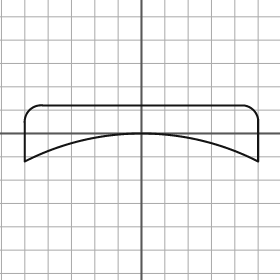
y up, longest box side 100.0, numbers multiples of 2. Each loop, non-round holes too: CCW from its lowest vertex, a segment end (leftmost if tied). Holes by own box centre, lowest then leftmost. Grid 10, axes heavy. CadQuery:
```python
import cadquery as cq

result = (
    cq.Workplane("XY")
    .moveTo(-50.0, -12.0)
    .threePointArc((0.0, 0.0), (50.0, -12.0))
    .lineTo(50.0, 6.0)
    .threePointArc((48.0, 10.0), (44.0, 12.0))
    .lineTo(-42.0, 12.0)
    .threePointArc((-48.0, 10.0), (-50.0, 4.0))
    .close()
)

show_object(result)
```